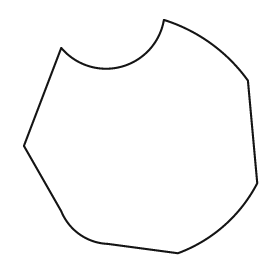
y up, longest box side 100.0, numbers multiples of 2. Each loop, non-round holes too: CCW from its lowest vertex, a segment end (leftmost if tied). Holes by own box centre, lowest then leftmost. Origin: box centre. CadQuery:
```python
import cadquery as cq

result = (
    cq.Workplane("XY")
    .moveTo(16.0, -50.0)
    .threePointArc((36.0, -38.0), (50.0, -20.0))
    .lineTo(46.0, 24.0)
    .threePointArc((30.0, 40.0), (10.0, 50.0))
    .threePointArc((-8.0, 30.0), (-34.0, 38.0))
    .lineTo(-50.0, -4.0)
    .lineTo(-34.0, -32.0)
    .threePointArc((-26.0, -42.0), (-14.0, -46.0))
    .close()
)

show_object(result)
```